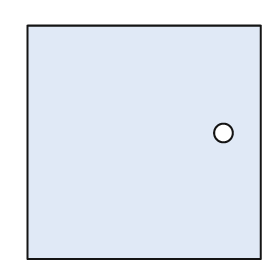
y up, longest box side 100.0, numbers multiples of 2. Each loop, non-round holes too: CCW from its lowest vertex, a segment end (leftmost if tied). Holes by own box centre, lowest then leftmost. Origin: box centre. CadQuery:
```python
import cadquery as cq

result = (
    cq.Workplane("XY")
    .moveTo(-50.0, -50.0)
    .lineTo(50.0, -50.0)
    .lineTo(50.0, 50.0)
    .lineTo(-50.0, 50.0)
    .close()
    .moveTo(34.0, 4.0)
    .circle(4.0)
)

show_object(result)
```